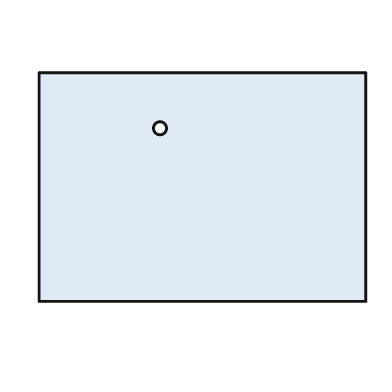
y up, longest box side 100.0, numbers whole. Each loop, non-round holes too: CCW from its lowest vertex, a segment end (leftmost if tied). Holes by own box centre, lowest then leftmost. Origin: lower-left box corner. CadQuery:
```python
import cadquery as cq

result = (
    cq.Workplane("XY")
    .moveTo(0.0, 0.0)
    .lineTo(100.0, 0.0)
    .lineTo(100.0, 70.0)
    .lineTo(0.0, 70.0)
    .close()
    .moveTo(37.0, 53.0)
    .circle(2.0)
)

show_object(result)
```